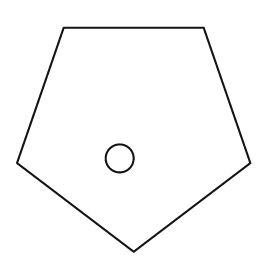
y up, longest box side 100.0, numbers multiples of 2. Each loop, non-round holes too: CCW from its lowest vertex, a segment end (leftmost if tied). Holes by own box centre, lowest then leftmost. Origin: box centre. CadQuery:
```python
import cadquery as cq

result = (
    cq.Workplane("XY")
    .moveTo(0.0, -48.0)
    .lineTo(50.0, -10.0)
    .lineTo(30.0, 48.0)
    .lineTo(-30.0, 48.0)
    .lineTo(-50.0, -10.0)
    .close()
    .moveTo(-6.0, -8.0)
    .circle(6.0)
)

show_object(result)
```